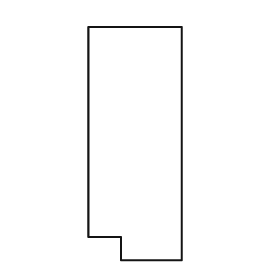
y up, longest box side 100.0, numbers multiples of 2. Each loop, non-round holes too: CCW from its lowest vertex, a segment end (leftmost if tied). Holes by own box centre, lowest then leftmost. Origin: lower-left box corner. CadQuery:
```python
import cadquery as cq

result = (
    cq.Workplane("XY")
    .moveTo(14.0, 0.0)
    .lineTo(40.0, 0.0)
    .lineTo(40.0, 100.0)
    .lineTo(0.0, 100.0)
    .lineTo(0.0, 10.0)
    .lineTo(14.0, 10.0)
    .close()
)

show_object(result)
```